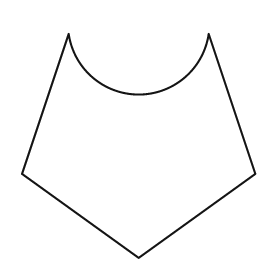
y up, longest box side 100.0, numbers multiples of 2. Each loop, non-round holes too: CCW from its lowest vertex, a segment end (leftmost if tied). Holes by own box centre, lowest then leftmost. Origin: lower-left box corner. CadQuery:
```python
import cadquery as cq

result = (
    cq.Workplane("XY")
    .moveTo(50.0, 0.0)
    .lineTo(100.0, 36.0)
    .lineTo(80.0, 96.0)
    .threePointArc((50.0, 70.0), (20.0, 96.0))
    .lineTo(0.0, 36.0)
    .close()
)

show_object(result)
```